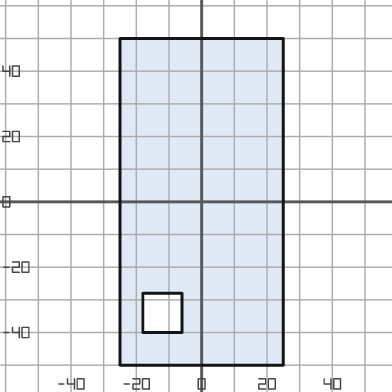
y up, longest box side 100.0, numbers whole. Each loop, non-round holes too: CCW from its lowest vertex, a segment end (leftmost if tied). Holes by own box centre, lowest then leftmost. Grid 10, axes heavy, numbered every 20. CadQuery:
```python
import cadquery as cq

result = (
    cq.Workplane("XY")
    .moveTo(-25.0, -50.0)
    .lineTo(25.0, -50.0)
    .lineTo(25.0, 50.0)
    .lineTo(-25.0, 50.0)
    .close()
    .moveTo(-18.0, -40.0)
    .lineTo(-6.0, -40.0)
    .lineTo(-6.0, -28.0)
    .lineTo(-18.0, -28.0)
    .close()
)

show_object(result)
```